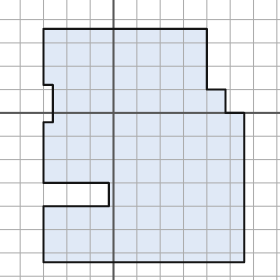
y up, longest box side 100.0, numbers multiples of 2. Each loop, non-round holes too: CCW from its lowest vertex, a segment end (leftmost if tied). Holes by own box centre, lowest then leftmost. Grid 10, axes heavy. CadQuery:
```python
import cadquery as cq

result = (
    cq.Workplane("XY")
    .moveTo(-30.0, -64.0)
    .lineTo(56.0, -64.0)
    .lineTo(56.0, 0.0)
    .lineTo(48.0, 0.0)
    .lineTo(48.0, 10.0)
    .lineTo(40.0, 10.0)
    .lineTo(40.0, 36.0)
    .lineTo(-30.0, 36.0)
    .lineTo(-30.0, 12.0)
    .lineTo(-26.0, 12.0)
    .lineTo(-26.0, -4.0)
    .lineTo(-30.0, -4.0)
    .lineTo(-30.0, -30.0)
    .lineTo(-2.0, -30.0)
    .lineTo(-2.0, -40.0)
    .lineTo(-30.0, -40.0)
    .close()
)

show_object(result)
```